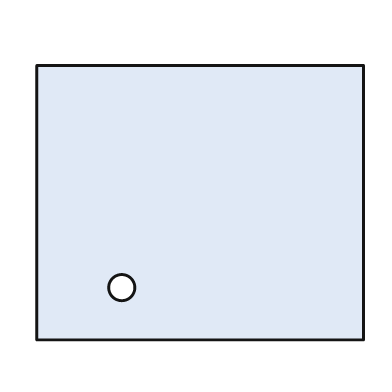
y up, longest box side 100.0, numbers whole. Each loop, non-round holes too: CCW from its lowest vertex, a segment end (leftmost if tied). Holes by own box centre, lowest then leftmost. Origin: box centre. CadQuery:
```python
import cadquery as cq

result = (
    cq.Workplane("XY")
    .moveTo(-50.0, -42.0)
    .lineTo(50.0, -42.0)
    .lineTo(50.0, 42.0)
    .lineTo(-50.0, 42.0)
    .close()
    .moveTo(-24.0, -26.0)
    .circle(4.0)
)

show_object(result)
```